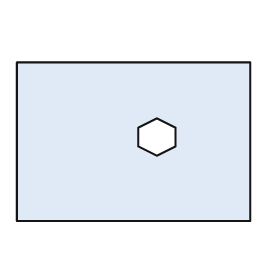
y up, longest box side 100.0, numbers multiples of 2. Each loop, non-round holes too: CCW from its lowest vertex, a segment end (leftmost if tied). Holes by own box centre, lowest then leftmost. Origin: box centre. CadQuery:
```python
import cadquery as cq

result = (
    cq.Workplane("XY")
    .moveTo(-50.0, -34.0)
    .lineTo(50.0, -34.0)
    .lineTo(50.0, 34.0)
    .lineTo(-50.0, 34.0)
    .close()
    .moveTo(10.0, -6.0)
    .lineTo(18.0, -2.0)
    .lineTo(18.0, 6.0)
    .lineTo(10.0, 10.0)
    .lineTo(2.0, 6.0)
    .lineTo(2.0, -2.0)
    .close()
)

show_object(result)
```